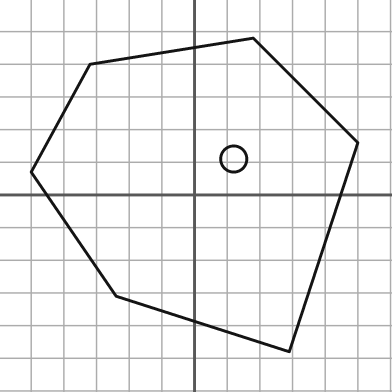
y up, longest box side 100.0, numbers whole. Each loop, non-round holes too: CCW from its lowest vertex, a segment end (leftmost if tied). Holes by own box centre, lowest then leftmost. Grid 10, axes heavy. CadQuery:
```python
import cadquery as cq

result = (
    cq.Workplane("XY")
    .moveTo(29.0, -48.0)
    .lineTo(50.0, 16.0)
    .lineTo(18.0, 48.0)
    .lineTo(-32.0, 40.0)
    .lineTo(-50.0, 7.0)
    .lineTo(-24.0, -31.0)
    .close()
    .moveTo(12.0, 11.0)
    .circle(4.0)
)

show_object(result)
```